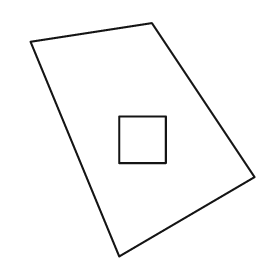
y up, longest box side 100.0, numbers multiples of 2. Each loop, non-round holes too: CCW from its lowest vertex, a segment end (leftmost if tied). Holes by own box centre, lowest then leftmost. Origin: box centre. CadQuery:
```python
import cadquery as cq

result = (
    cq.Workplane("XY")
    .moveTo(-10.0, -50.0)
    .lineTo(48.0, -16.0)
    .lineTo(4.0, 50.0)
    .lineTo(-48.0, 42.0)
    .close()
    .moveTo(-10.0, -10.0)
    .lineTo(10.0, -10.0)
    .lineTo(10.0, 10.0)
    .lineTo(-10.0, 10.0)
    .close()
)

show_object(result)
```